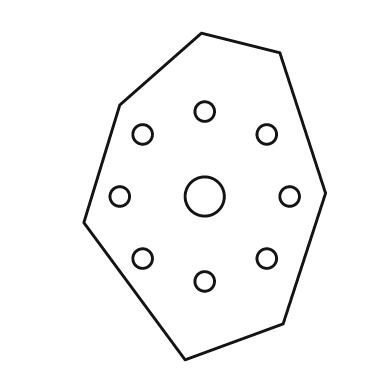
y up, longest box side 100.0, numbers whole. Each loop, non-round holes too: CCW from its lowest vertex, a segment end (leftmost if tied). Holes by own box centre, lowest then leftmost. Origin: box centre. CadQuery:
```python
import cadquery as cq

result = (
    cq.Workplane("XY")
    .moveTo(-6.0, -50.0)
    .lineTo(24.0, -39.0)
    .lineTo(37.0, 1.0)
    .lineTo(23.0, 44.0)
    .lineTo(-1.0, 50.0)
    .lineTo(-26.0, 28.0)
    .lineTo(-37.0, -8.0)
    .close()
    .moveTo(0.0, -26.0)
    .circle(3.0)
    .moveTo(-19.0, -19.0)
    .circle(3.0)
    .moveTo(19.0, -19.0)
    .circle(3.0)
    .moveTo(-26.0, 0.0)
    .circle(3.0)
    .moveTo(0.0, 0.0)
    .circle(6.0)
    .moveTo(26.0, 0.0)
    .circle(3.0)
    .moveTo(-19.0, 19.0)
    .circle(3.0)
    .moveTo(19.0, 19.0)
    .circle(3.0)
    .moveTo(0.0, 26.0)
    .circle(3.0)
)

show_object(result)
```